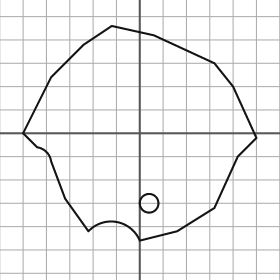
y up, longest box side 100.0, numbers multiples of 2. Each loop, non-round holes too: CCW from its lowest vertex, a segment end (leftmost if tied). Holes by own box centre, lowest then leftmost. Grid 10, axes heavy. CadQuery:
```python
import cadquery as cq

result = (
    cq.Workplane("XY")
    .moveTo(0.0, -46.0)
    .lineTo(16.0, -42.0)
    .lineTo(32.0, -32.0)
    .lineTo(42.0, -10.0)
    .lineTo(50.0, -2.0)
    .lineTo(40.0, 20.0)
    .lineTo(32.0, 30.0)
    .lineTo(6.0, 42.0)
    .lineTo(-12.0, 46.0)
    .lineTo(-24.0, 38.0)
    .lineTo(-38.0, 24.0)
    .lineTo(-50.0, 0.0)
    .lineTo(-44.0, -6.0)
    .threePointArc((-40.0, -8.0), (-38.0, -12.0))
    .lineTo(-32.0, -28.0)
    .lineTo(-22.0, -42.0)
    .threePointArc((-10.0, -38.0), (0.0, -46.0))
    .close()
    .moveTo(4.0, -30.0)
    .circle(4.0)
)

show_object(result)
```